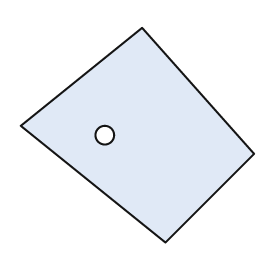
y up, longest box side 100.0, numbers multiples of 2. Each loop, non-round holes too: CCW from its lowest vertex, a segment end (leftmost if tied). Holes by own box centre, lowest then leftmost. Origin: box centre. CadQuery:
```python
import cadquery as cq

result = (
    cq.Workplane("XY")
    .moveTo(12.0, -46.0)
    .lineTo(50.0, -8.0)
    .lineTo(2.0, 46.0)
    .lineTo(-50.0, 4.0)
    .close()
    .moveTo(-14.0, 0.0)
    .circle(4.0)
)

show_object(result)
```